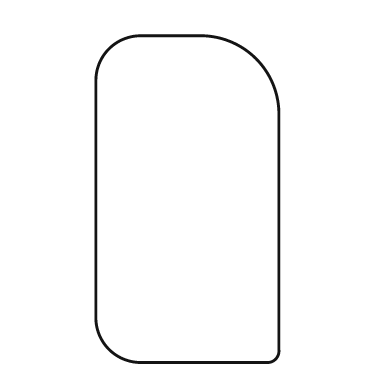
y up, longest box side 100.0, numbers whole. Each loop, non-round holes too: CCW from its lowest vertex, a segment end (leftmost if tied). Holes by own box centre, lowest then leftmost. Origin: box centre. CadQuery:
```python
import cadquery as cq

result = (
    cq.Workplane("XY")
    .moveTo(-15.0, -50.0)
    .lineTo(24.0, -50.0)
    .threePointArc((27.0, -49.0), (28.0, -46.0))
    .lineTo(28.0, 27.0)
    .threePointArc((21.0, 43.0), (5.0, 50.0))
    .lineTo(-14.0, 50.0)
    .threePointArc((-24.0, 46.0), (-28.0, 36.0))
    .lineTo(-28.0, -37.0)
    .threePointArc((-24.0, -46.0), (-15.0, -50.0))
    .close()
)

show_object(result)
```